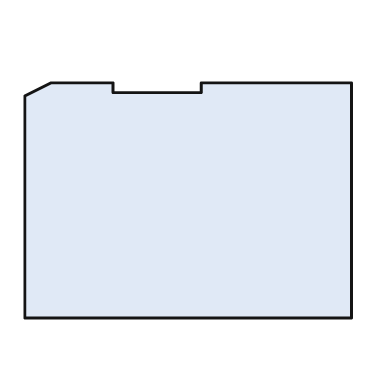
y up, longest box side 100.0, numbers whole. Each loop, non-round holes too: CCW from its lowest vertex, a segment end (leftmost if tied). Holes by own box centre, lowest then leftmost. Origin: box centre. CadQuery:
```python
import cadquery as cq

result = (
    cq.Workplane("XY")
    .moveTo(-50.0, -36.0)
    .lineTo(50.0, -36.0)
    .lineTo(50.0, 36.0)
    .lineTo(4.0, 36.0)
    .lineTo(4.0, 33.0)
    .lineTo(-23.0, 33.0)
    .lineTo(-23.0, 36.0)
    .lineTo(-42.0, 36.0)
    .lineTo(-50.0, 32.0)
    .close()
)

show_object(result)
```